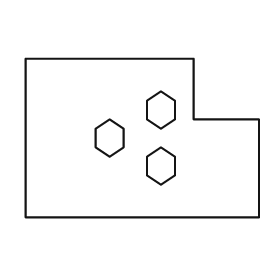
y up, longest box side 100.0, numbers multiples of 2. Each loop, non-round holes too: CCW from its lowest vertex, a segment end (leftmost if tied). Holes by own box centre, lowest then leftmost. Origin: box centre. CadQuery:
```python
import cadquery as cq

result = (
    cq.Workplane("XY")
    .moveTo(-50.0, -34.0)
    .lineTo(50.0, -34.0)
    .lineTo(50.0, 8.0)
    .lineTo(22.0, 8.0)
    .lineTo(22.0, 34.0)
    .lineTo(-50.0, 34.0)
    .close()
    .moveTo(8.0, -20.0)
    .lineTo(14.0, -16.0)
    .lineTo(14.0, -8.0)
    .lineTo(8.0, -4.0)
    .lineTo(2.0, -8.0)
    .lineTo(2.0, -16.0)
    .close()
    .moveTo(-14.0, -8.0)
    .lineTo(-8.0, -4.0)
    .lineTo(-8.0, 4.0)
    .lineTo(-14.0, 8.0)
    .lineTo(-20.0, 4.0)
    .lineTo(-20.0, -4.0)
    .close()
    .moveTo(8.0, 4.0)
    .lineTo(14.0, 8.0)
    .lineTo(14.0, 16.0)
    .lineTo(8.0, 20.0)
    .lineTo(2.0, 16.0)
    .lineTo(2.0, 8.0)
    .close()
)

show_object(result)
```